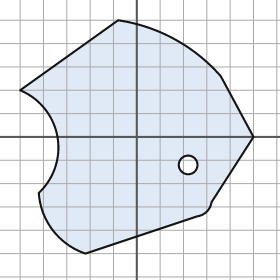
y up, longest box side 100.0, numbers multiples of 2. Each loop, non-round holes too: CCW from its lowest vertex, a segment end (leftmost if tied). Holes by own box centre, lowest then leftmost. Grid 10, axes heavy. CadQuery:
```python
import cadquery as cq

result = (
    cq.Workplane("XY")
    .moveTo(-22.0, -50.0)
    .lineTo(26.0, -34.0)
    .threePointArc((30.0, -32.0), (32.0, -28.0))
    .lineTo(50.0, 0.0)
    .lineTo(36.0, 26.0)
    .threePointArc((16.0, 42.0), (-8.0, 50.0))
    .lineTo(-50.0, 20.0)
    .threePointArc((-34.0, 0.0), (-42.0, -24.0))
    .threePointArc((-36.0, -40.0), (-22.0, -50.0))
    .close()
    .moveTo(22.0, -12.0)
    .circle(4.0)
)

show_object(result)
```